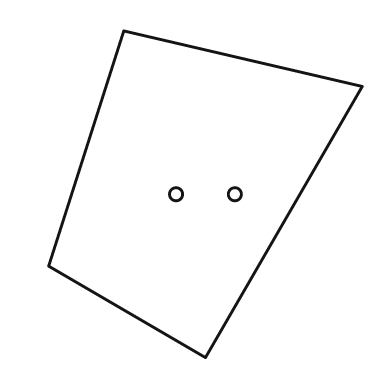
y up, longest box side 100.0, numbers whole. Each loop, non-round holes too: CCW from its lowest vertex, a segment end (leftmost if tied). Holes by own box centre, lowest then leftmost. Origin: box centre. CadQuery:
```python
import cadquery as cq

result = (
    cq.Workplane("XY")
    .moveTo(0.0, -50.0)
    .lineTo(48.0, 33.0)
    .lineTo(-25.0, 50.0)
    .lineTo(-48.0, -22.0)
    .close()
    .moveTo(-9.0, 0.0)
    .circle(2.0)
    .moveTo(9.0, 0.0)
    .circle(2.0)
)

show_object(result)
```